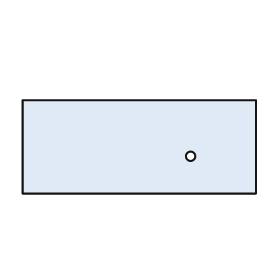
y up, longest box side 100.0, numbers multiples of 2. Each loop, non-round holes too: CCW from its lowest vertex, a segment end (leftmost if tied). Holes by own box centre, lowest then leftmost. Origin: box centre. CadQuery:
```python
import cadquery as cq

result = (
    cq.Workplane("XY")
    .moveTo(-50.0, -20.0)
    .lineTo(50.0, -20.0)
    .lineTo(50.0, 20.0)
    .lineTo(-50.0, 20.0)
    .close()
    .moveTo(22.0, -4.0)
    .circle(2.0)
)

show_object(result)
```